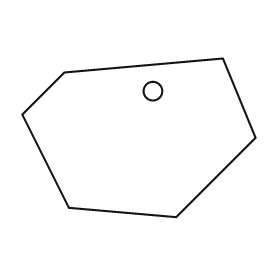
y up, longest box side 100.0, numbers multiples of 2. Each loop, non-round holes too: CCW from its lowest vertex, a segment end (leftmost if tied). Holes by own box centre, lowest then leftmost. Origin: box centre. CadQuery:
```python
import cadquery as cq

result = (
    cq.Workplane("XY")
    .moveTo(16.0, -34.0)
    .lineTo(50.0, 0.0)
    .lineTo(36.0, 34.0)
    .lineTo(-32.0, 28.0)
    .lineTo(-50.0, 10.0)
    .lineTo(-30.0, -30.0)
    .close()
    .moveTo(6.0, 20.0)
    .circle(4.0)
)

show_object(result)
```